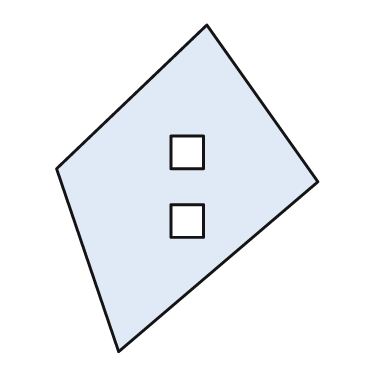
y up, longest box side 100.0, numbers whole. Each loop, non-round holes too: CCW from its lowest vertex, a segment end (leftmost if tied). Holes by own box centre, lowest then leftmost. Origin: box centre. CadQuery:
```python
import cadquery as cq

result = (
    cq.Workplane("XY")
    .moveTo(-21.0, -50.0)
    .lineTo(40.0, 2.0)
    .lineTo(6.0, 50.0)
    .lineTo(-40.0, 6.0)
    .close()
    .moveTo(-5.0, -15.0)
    .lineTo(5.0, -15.0)
    .lineTo(5.0, -5.0)
    .lineTo(-5.0, -5.0)
    .close()
    .moveTo(-5.0, 6.0)
    .lineTo(5.0, 6.0)
    .lineTo(5.0, 16.0)
    .lineTo(-5.0, 16.0)
    .close()
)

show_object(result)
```